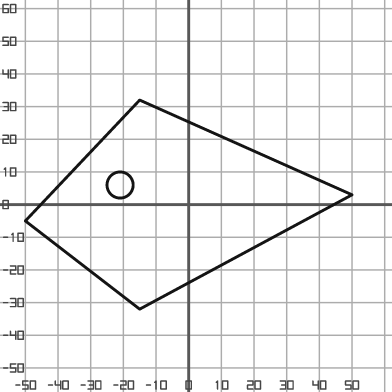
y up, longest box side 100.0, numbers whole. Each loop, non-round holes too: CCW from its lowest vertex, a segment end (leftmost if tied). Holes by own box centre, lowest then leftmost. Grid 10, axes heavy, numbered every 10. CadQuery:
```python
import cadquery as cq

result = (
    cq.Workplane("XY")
    .moveTo(-15.0, -32.0)
    .lineTo(50.0, 3.0)
    .lineTo(-15.0, 32.0)
    .lineTo(-50.0, -5.0)
    .close()
    .moveTo(-21.0, 6.0)
    .circle(4.0)
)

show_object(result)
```